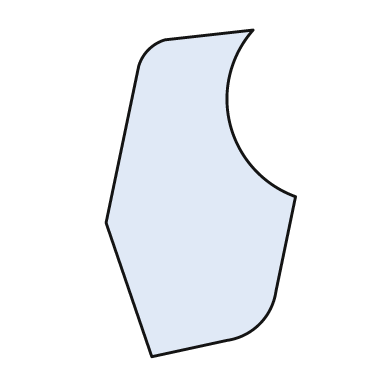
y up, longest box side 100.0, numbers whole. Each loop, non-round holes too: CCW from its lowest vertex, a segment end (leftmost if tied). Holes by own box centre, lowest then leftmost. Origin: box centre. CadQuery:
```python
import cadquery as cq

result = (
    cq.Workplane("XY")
    .moveTo(-15.0, -50.0)
    .lineTo(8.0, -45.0)
    .threePointArc((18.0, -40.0), (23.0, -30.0))
    .lineTo(29.0, -1.0)
    .threePointArc((9.0, 21.0), (16.0, 50.0))
    .lineTo(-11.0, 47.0)
    .threePointArc((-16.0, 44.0), (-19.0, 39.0))
    .lineTo(-29.0, -9.0)
    .close()
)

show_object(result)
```